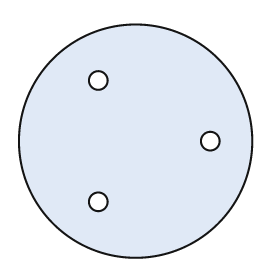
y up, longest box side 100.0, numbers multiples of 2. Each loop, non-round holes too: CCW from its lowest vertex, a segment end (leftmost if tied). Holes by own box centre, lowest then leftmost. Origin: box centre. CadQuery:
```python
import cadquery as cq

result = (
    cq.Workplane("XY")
    .moveTo(0.0, 0.0)
    .circle(50.0)
    .moveTo(-16.0, -26.0)
    .circle(4.0)
    .moveTo(32.0, 0.0)
    .circle(4.0)
    .moveTo(-16.0, 26.0)
    .circle(4.0)
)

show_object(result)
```